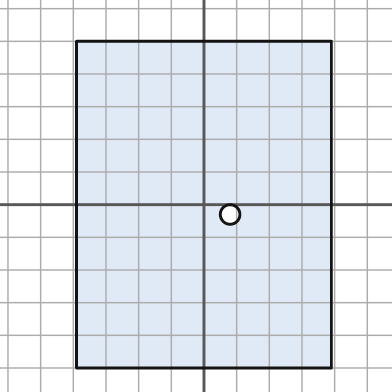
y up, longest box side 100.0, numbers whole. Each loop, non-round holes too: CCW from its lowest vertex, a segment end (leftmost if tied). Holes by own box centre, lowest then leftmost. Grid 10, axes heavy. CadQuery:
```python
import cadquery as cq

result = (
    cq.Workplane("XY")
    .moveTo(-39.0, -50.0)
    .lineTo(39.0, -50.0)
    .lineTo(39.0, 50.0)
    .lineTo(-39.0, 50.0)
    .close()
    .moveTo(8.0, -3.0)
    .circle(3.0)
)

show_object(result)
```